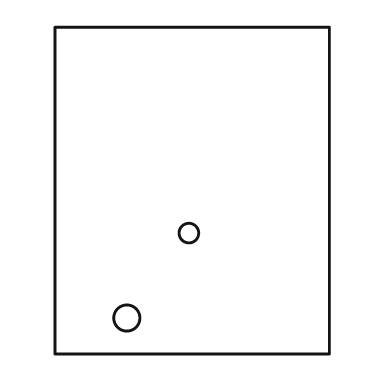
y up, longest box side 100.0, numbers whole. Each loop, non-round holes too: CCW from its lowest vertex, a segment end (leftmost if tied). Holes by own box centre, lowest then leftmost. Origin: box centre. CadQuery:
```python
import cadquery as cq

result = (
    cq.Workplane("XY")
    .moveTo(-42.0, -50.0)
    .lineTo(42.0, -50.0)
    .lineTo(42.0, 50.0)
    .lineTo(-42.0, 50.0)
    .close()
    .moveTo(-20.0, -39.0)
    .circle(4.0)
    .moveTo(-1.0, -13.0)
    .circle(3.0)
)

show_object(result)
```